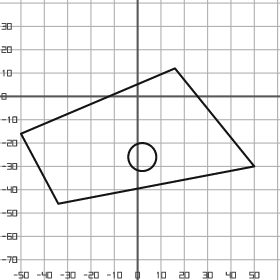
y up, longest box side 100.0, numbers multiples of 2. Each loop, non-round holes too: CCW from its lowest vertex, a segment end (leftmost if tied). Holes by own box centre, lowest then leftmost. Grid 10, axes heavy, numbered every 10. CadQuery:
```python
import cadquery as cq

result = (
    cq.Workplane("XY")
    .moveTo(-34.0, -46.0)
    .lineTo(50.0, -30.0)
    .lineTo(16.0, 12.0)
    .lineTo(-50.0, -16.0)
    .close()
    .moveTo(2.0, -26.0)
    .circle(6.0)
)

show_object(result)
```